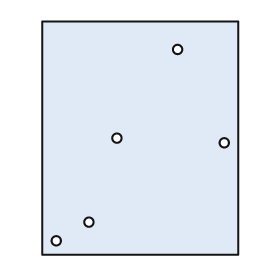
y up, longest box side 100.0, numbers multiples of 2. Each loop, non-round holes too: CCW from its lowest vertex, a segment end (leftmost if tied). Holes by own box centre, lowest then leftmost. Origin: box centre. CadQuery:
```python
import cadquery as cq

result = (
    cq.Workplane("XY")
    .moveTo(-42.0, -50.0)
    .lineTo(42.0, -50.0)
    .lineTo(42.0, 50.0)
    .lineTo(-42.0, 50.0)
    .close()
    .moveTo(-36.0, -44.0)
    .circle(2.0)
    .moveTo(-22.0, -36.0)
    .circle(2.0)
    .moveTo(36.0, -2.0)
    .circle(2.0)
    .moveTo(-10.0, 0.0)
    .circle(2.0)
    .moveTo(16.0, 38.0)
    .circle(2.0)
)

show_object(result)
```